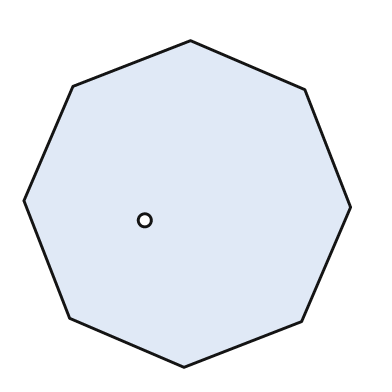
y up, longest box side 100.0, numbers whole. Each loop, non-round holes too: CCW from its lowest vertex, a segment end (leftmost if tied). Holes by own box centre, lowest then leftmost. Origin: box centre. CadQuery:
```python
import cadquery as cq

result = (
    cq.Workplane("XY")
    .moveTo(-1.0, -50.0)
    .lineTo(35.0, -36.0)
    .lineTo(50.0, -1.0)
    .lineTo(36.0, 35.0)
    .lineTo(1.0, 50.0)
    .lineTo(-35.0, 36.0)
    .lineTo(-50.0, 1.0)
    .lineTo(-36.0, -35.0)
    .close()
    .moveTo(-13.0, -5.0)
    .circle(2.0)
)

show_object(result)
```